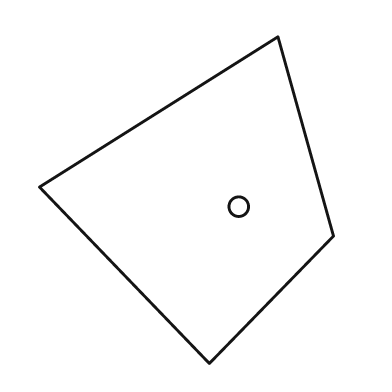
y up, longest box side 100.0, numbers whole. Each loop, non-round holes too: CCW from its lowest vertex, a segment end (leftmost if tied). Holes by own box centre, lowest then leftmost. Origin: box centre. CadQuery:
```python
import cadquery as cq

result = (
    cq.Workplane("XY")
    .moveTo(7.0, -50.0)
    .lineTo(45.0, -11.0)
    .lineTo(28.0, 50.0)
    .lineTo(-45.0, 4.0)
    .close()
    .moveTo(16.0, -2.0)
    .circle(3.0)
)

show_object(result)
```